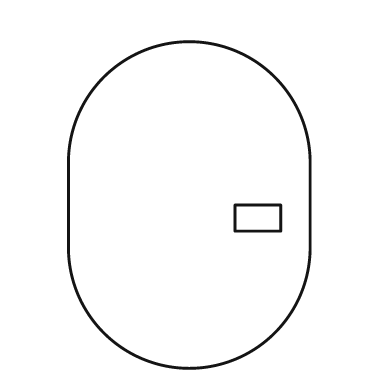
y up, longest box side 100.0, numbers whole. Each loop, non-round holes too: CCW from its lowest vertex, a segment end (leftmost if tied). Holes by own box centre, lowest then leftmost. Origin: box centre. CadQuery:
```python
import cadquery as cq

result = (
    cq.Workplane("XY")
    .moveTo(-37.0, -13.0)
    .threePointArc((0.0, -50.0), (37.0, -13.0))
    .lineTo(37.0, 13.0)
    .threePointArc((0.0, 50.0), (-37.0, 13.0))
    .close()
    .moveTo(14.0, -8.0)
    .lineTo(28.0, -8.0)
    .lineTo(28.0, 0.0)
    .lineTo(14.0, 0.0)
    .close()
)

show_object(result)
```